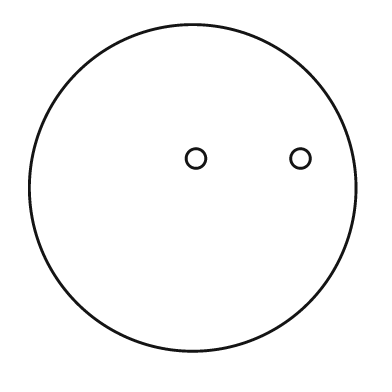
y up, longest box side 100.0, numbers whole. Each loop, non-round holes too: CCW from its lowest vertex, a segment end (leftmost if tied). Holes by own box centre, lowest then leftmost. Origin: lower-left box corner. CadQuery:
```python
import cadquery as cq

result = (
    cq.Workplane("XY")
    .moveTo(50.0, 50.0)
    .circle(50.0)
    .moveTo(51.0, 59.0)
    .circle(3.0)
    .moveTo(83.0, 59.0)
    .circle(3.0)
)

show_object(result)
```